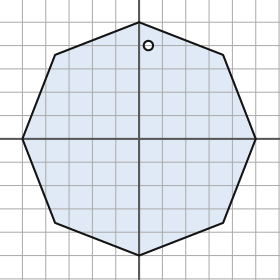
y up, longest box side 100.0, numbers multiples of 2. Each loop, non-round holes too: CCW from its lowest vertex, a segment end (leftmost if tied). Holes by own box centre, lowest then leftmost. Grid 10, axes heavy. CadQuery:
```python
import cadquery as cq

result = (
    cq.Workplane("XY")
    .moveTo(0.0, -50.0)
    .lineTo(36.0, -36.0)
    .lineTo(50.0, 0.0)
    .lineTo(36.0, 36.0)
    .lineTo(0.0, 50.0)
    .lineTo(-36.0, 36.0)
    .lineTo(-50.0, 0.0)
    .lineTo(-36.0, -36.0)
    .close()
    .moveTo(4.0, 40.0)
    .circle(2.0)
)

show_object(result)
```